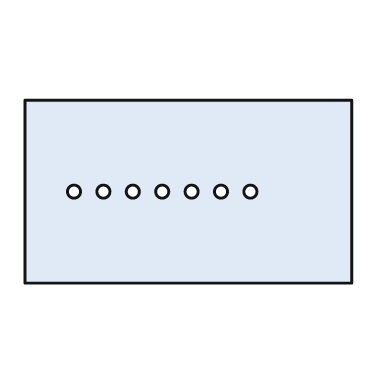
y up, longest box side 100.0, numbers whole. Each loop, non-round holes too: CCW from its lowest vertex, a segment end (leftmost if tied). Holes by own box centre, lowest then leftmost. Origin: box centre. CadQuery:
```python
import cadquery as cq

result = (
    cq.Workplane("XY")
    .moveTo(-50.0, -28.0)
    .lineTo(50.0, -28.0)
    .lineTo(50.0, 28.0)
    .lineTo(-50.0, 28.0)
    .close()
    .moveTo(-35.0, 0.0)
    .circle(2.0)
    .moveTo(-26.0, 0.0)
    .circle(2.0)
    .moveTo(-17.0, 0.0)
    .circle(2.0)
    .moveTo(-8.0, 0.0)
    .circle(2.0)
    .moveTo(1.0, 0.0)
    .circle(2.0)
    .moveTo(10.0, 0.0)
    .circle(2.0)
    .moveTo(19.0, 0.0)
    .circle(2.0)
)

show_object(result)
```